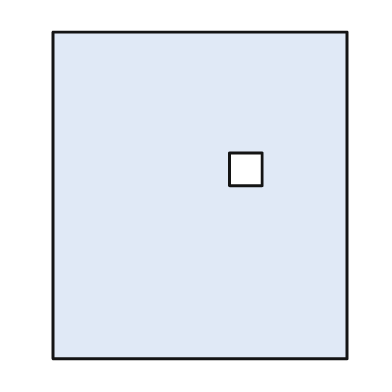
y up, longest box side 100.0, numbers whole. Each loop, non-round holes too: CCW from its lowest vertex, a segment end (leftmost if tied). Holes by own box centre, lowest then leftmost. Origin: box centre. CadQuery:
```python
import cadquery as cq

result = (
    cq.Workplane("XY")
    .moveTo(-45.0, -50.0)
    .lineTo(45.0, -50.0)
    .lineTo(45.0, 50.0)
    .lineTo(-45.0, 50.0)
    .close()
    .moveTo(9.0, 3.0)
    .lineTo(19.0, 3.0)
    .lineTo(19.0, 13.0)
    .lineTo(9.0, 13.0)
    .close()
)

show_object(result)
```